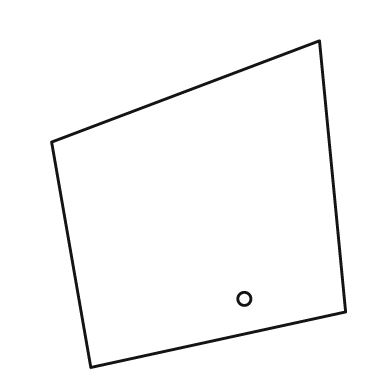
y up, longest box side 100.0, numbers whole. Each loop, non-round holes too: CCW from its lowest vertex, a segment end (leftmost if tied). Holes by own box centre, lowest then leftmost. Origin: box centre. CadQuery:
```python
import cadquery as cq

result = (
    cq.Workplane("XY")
    .moveTo(-33.0, -50.0)
    .lineTo(45.0, -33.0)
    .lineTo(37.0, 50.0)
    .lineTo(-45.0, 19.0)
    .close()
    .moveTo(14.0, -29.0)
    .circle(2.0)
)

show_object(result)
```